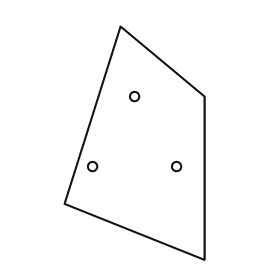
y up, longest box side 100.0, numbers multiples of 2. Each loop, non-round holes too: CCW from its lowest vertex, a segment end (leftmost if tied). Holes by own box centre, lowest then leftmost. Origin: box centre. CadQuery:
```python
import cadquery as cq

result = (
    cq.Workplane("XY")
    .moveTo(30.0, -50.0)
    .lineTo(30.0, 20.0)
    .lineTo(-6.0, 50.0)
    .lineTo(-30.0, -26.0)
    .close()
    .moveTo(-18.0, -10.0)
    .circle(2.0)
    .moveTo(18.0, -10.0)
    .circle(2.0)
    .moveTo(0.0, 20.0)
    .circle(2.0)
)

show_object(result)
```